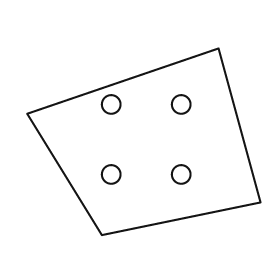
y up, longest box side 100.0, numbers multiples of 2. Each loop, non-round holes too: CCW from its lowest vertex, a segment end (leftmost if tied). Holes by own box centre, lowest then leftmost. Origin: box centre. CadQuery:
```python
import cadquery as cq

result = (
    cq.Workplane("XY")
    .moveTo(-18.0, -40.0)
    .lineTo(50.0, -26.0)
    .lineTo(32.0, 40.0)
    .lineTo(-50.0, 12.0)
    .close()
    .moveTo(-14.0, -14.0)
    .circle(4.0)
    .moveTo(16.0, -14.0)
    .circle(4.0)
    .moveTo(-14.0, 16.0)
    .circle(4.0)
    .moveTo(16.0, 16.0)
    .circle(4.0)
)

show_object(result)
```